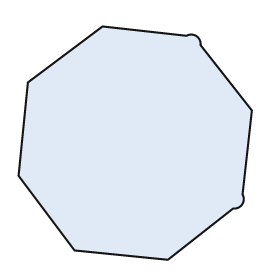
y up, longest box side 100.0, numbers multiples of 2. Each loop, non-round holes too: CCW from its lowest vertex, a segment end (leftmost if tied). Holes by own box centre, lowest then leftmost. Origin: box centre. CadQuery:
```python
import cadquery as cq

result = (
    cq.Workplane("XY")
    .moveTo(14.0, -50.0)
    .lineTo(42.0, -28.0)
    .threePointArc((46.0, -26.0), (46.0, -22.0))
    .lineTo(50.0, 14.0)
    .lineTo(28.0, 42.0)
    .threePointArc((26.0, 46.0), (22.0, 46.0))
    .lineTo(-14.0, 50.0)
    .lineTo(-46.0, 26.0)
    .lineTo(-50.0, -14.0)
    .lineTo(-26.0, -46.0)
    .close()
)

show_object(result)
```